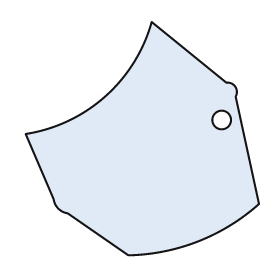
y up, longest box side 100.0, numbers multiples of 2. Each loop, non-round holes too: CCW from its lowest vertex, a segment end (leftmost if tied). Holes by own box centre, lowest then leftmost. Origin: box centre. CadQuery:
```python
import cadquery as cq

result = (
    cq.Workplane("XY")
    .moveTo(-6.0, -50.0)
    .threePointArc((24.0, -44.0), (50.0, -28.0))
    .lineTo(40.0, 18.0)
    .threePointArc((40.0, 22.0), (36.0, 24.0))
    .lineTo(4.0, 50.0)
    .threePointArc((-16.0, 18.0), (-50.0, 2.0))
    .lineTo(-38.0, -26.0)
    .threePointArc((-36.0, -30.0), (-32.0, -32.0))
    .close()
    .moveTo(34.0, 8.0)
    .circle(4.0)
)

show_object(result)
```